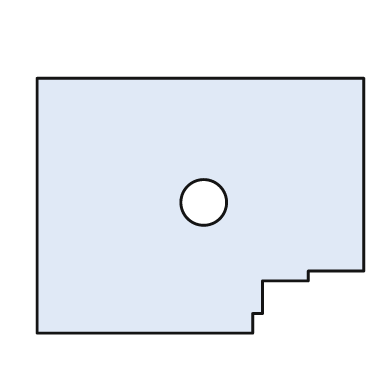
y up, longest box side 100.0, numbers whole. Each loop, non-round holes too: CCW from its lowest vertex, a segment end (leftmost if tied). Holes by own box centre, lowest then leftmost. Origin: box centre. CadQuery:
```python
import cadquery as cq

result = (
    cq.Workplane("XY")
    .moveTo(-50.0, -39.0)
    .lineTo(16.0, -39.0)
    .lineTo(16.0, -33.0)
    .lineTo(19.0, -33.0)
    .lineTo(19.0, -23.0)
    .lineTo(33.0, -23.0)
    .lineTo(33.0, -20.0)
    .lineTo(50.0, -20.0)
    .lineTo(50.0, 39.0)
    .lineTo(-50.0, 39.0)
    .close()
    .moveTo(1.0, 1.0)
    .circle(7.0)
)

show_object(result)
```